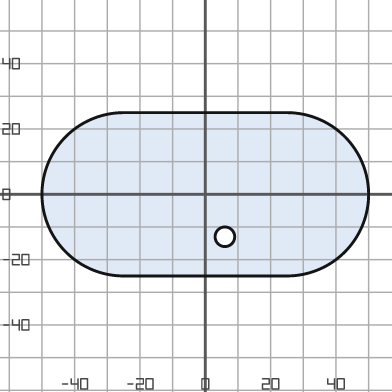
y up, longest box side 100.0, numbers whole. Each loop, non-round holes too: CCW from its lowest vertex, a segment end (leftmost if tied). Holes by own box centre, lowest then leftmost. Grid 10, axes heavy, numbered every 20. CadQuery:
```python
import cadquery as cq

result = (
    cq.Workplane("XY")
    .moveTo(-25.0, -25.0)
    .lineTo(25.0, -25.0)
    .threePointArc((50.0, 0.0), (25.0, 25.0))
    .lineTo(-25.0, 25.0)
    .threePointArc((-50.0, 0.0), (-25.0, -25.0))
    .close()
    .moveTo(6.0, -13.0)
    .circle(3.0)
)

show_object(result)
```